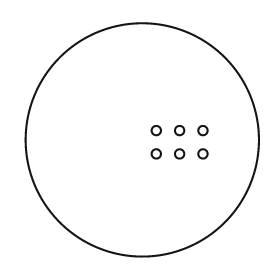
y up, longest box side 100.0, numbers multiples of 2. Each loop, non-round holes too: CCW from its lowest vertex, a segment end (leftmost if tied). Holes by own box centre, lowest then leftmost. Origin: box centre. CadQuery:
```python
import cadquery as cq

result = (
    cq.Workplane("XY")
    .moveTo(0.0, 0.0)
    .circle(50.0)
    .moveTo(6.0, -6.0)
    .circle(2.0)
    .moveTo(16.0, -6.0)
    .circle(2.0)
    .moveTo(26.0, -6.0)
    .circle(2.0)
    .moveTo(6.0, 4.0)
    .circle(2.0)
    .moveTo(16.0, 4.0)
    .circle(2.0)
    .moveTo(26.0, 4.0)
    .circle(2.0)
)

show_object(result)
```